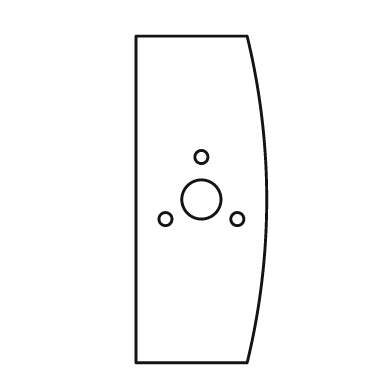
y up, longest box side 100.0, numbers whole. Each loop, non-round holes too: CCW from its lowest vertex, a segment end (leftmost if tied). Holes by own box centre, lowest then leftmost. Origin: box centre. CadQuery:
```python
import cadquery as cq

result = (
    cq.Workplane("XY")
    .moveTo(-20.0, -50.0)
    .lineTo(14.0, -50.0)
    .threePointArc((20.0, 0.0), (14.0, 50.0))
    .lineTo(-20.0, 50.0)
    .close()
    .moveTo(-11.0, -6.0)
    .circle(2.0)
    .moveTo(11.0, -6.0)
    .circle(2.0)
    .moveTo(0.0, 0.0)
    .circle(6.0)
    .moveTo(0.0, 13.0)
    .circle(2.0)
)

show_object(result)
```